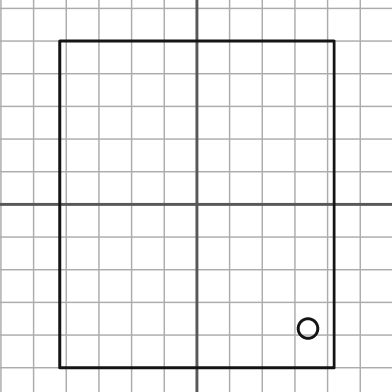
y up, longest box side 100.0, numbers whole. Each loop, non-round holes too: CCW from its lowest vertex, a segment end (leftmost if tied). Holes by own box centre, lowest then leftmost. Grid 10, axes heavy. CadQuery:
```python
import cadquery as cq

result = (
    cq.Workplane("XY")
    .moveTo(-42.0, -50.0)
    .lineTo(42.0, -50.0)
    .lineTo(42.0, 50.0)
    .lineTo(-42.0, 50.0)
    .close()
    .moveTo(34.0, -38.0)
    .circle(3.0)
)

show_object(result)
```